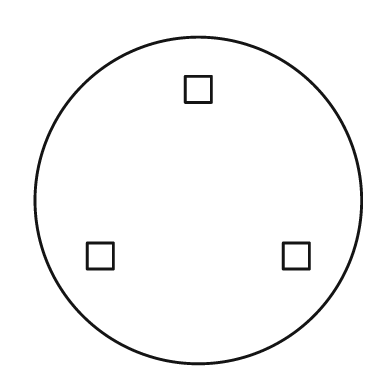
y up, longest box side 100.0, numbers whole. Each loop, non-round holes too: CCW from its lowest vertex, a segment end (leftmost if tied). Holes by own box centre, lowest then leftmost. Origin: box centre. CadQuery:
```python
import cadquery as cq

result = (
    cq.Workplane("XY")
    .moveTo(0.0, 0.0)
    .circle(50.0)
    .moveTo(-34.0, -21.0)
    .lineTo(-26.0, -21.0)
    .lineTo(-26.0, -13.0)
    .lineTo(-34.0, -13.0)
    .close()
    .moveTo(26.0, -21.0)
    .lineTo(34.0, -21.0)
    .lineTo(34.0, -13.0)
    .lineTo(26.0, -13.0)
    .close()
    .moveTo(-4.0, 30.0)
    .lineTo(4.0, 30.0)
    .lineTo(4.0, 38.0)
    .lineTo(-4.0, 38.0)
    .close()
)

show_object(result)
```